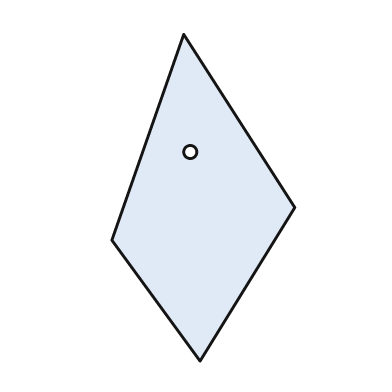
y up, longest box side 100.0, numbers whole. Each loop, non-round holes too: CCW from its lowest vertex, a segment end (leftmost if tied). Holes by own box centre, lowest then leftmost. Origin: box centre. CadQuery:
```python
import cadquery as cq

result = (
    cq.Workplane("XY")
    .moveTo(-1.0, -50.0)
    .lineTo(28.0, -3.0)
    .lineTo(-6.0, 50.0)
    .lineTo(-28.0, -13.0)
    .close()
    .moveTo(-4.0, 14.0)
    .circle(2.0)
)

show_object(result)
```